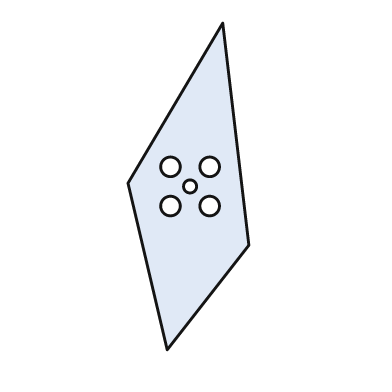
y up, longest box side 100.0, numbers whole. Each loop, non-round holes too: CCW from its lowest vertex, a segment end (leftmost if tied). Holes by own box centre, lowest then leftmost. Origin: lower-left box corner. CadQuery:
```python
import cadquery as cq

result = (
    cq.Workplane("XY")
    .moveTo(12.0, 0.0)
    .lineTo(37.0, 32.0)
    .lineTo(29.0, 100.0)
    .lineTo(0.0, 51.0)
    .close()
    .moveTo(13.0, 44.0)
    .circle(3.0)
    .moveTo(25.0, 44.0)
    .circle(3.0)
    .moveTo(19.0, 50.0)
    .circle(2.0)
    .moveTo(13.0, 56.0)
    .circle(3.0)
    .moveTo(25.0, 56.0)
    .circle(3.0)
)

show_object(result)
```